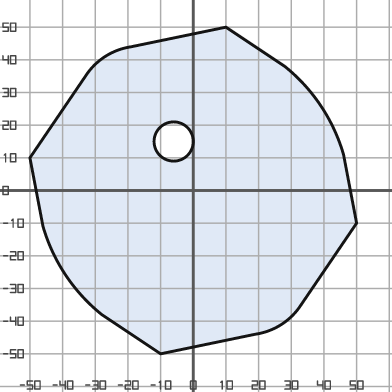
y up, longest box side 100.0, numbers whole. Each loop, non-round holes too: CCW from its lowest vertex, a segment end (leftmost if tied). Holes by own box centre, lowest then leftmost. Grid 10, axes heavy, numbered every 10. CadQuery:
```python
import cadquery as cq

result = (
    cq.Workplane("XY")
    .moveTo(-10.0, -50.0)
    .lineTo(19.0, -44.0)
    .threePointArc((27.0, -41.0), (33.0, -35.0))
    .lineTo(50.0, -10.0)
    .lineTo(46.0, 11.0)
    .threePointArc((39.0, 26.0), (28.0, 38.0))
    .lineTo(10.0, 50.0)
    .lineTo(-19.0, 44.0)
    .threePointArc((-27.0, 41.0), (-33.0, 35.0))
    .lineTo(-50.0, 10.0)
    .lineTo(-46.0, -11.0)
    .threePointArc((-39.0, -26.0), (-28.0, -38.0))
    .close()
    .moveTo(-6.0, 15.0)
    .circle(6.0)
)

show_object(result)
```